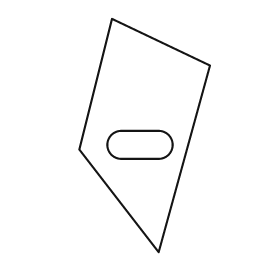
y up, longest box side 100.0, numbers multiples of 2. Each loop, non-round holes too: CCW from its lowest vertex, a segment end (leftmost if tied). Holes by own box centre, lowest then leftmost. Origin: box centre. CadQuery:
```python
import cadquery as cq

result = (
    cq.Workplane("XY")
    .moveTo(6.0, -50.0)
    .lineTo(28.0, 30.0)
    .lineTo(-14.0, 50.0)
    .lineTo(-28.0, -6.0)
    .close()
    .moveTo(-10.0, -10.0)
    .lineTo(6.0, -10.0)
    .threePointArc((12.0, -4.0), (6.0, 2.0))
    .lineTo(-10.0, 2.0)
    .threePointArc((-16.0, -4.0), (-10.0, -10.0))
    .close()
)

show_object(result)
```